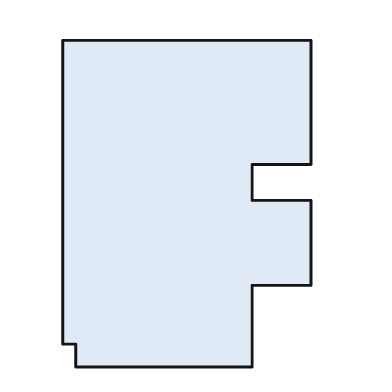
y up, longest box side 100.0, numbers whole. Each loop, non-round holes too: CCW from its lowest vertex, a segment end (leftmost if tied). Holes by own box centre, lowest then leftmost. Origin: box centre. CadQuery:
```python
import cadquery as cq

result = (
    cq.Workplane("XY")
    .moveTo(-34.0, -50.0)
    .lineTo(20.0, -50.0)
    .lineTo(20.0, -25.0)
    .lineTo(38.0, -25.0)
    .lineTo(38.0, 1.0)
    .lineTo(20.0, 1.0)
    .lineTo(20.0, 12.0)
    .lineTo(38.0, 12.0)
    .lineTo(38.0, 50.0)
    .lineTo(-38.0, 50.0)
    .lineTo(-38.0, -43.0)
    .lineTo(-34.0, -43.0)
    .close()
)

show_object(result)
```